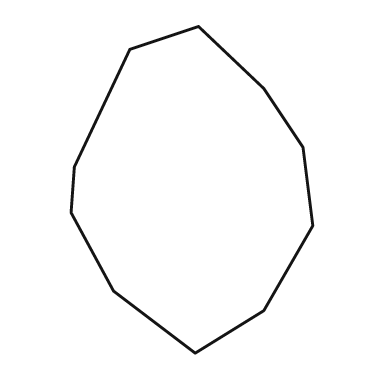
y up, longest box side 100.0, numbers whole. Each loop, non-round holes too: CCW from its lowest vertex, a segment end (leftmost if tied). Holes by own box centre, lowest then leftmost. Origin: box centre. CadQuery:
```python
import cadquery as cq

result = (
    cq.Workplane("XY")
    .moveTo(1.0, -50.0)
    .lineTo(22.0, -37.0)
    .lineTo(37.0, -11.0)
    .lineTo(34.0, 13.0)
    .lineTo(22.0, 31.0)
    .lineTo(2.0, 50.0)
    .lineTo(-19.0, 43.0)
    .lineTo(-36.0, 7.0)
    .lineTo(-37.0, -7.0)
    .lineTo(-24.0, -31.0)
    .close()
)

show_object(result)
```